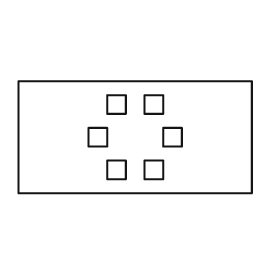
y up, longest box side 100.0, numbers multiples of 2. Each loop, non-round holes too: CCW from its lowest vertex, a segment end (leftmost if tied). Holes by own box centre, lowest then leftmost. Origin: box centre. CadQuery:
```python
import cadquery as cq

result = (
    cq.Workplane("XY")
    .moveTo(-50.0, -24.0)
    .lineTo(50.0, -24.0)
    .lineTo(50.0, 24.0)
    .lineTo(-50.0, 24.0)
    .close()
    .moveTo(-12.0, -18.0)
    .lineTo(-4.0, -18.0)
    .lineTo(-4.0, -10.0)
    .lineTo(-12.0, -10.0)
    .close()
    .moveTo(4.0, -18.0)
    .lineTo(12.0, -18.0)
    .lineTo(12.0, -10.0)
    .lineTo(4.0, -10.0)
    .close()
    .moveTo(-20.0, -4.0)
    .lineTo(-12.0, -4.0)
    .lineTo(-12.0, 4.0)
    .lineTo(-20.0, 4.0)
    .close()
    .moveTo(12.0, -4.0)
    .lineTo(20.0, -4.0)
    .lineTo(20.0, 4.0)
    .lineTo(12.0, 4.0)
    .close()
    .moveTo(-12.0, 10.0)
    .lineTo(-4.0, 10.0)
    .lineTo(-4.0, 18.0)
    .lineTo(-12.0, 18.0)
    .close()
    .moveTo(4.0, 10.0)
    .lineTo(12.0, 10.0)
    .lineTo(12.0, 18.0)
    .lineTo(4.0, 18.0)
    .close()
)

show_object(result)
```